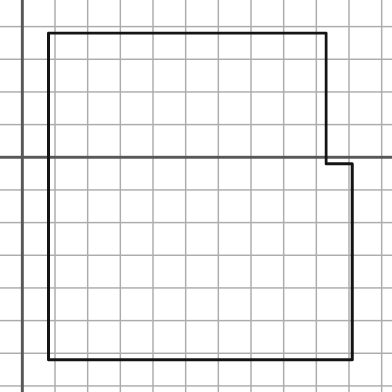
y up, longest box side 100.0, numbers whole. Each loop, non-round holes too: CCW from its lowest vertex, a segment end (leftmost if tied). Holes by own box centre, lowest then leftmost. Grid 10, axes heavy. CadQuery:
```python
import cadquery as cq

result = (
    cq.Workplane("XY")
    .moveTo(8.0, -62.0)
    .lineTo(101.0, -62.0)
    .lineTo(101.0, -2.0)
    .lineTo(93.0, -2.0)
    .lineTo(93.0, 38.0)
    .lineTo(8.0, 38.0)
    .close()
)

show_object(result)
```